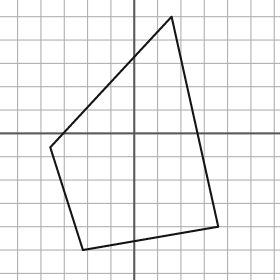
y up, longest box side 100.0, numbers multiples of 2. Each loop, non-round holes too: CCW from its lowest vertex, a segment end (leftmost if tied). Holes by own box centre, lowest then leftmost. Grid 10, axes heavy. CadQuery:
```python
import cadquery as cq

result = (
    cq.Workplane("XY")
    .moveTo(-22.0, -50.0)
    .lineTo(36.0, -40.0)
    .lineTo(16.0, 50.0)
    .lineTo(-36.0, -6.0)
    .close()
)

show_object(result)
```